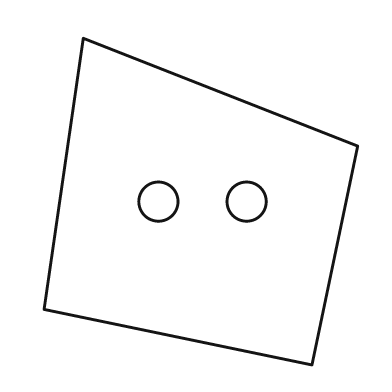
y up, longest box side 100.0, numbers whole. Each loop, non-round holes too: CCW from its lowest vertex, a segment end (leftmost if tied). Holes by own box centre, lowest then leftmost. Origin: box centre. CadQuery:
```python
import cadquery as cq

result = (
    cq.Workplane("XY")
    .moveTo(34.0, -50.0)
    .lineTo(48.0, 17.0)
    .lineTo(-36.0, 50.0)
    .lineTo(-48.0, -33.0)
    .close()
    .moveTo(-13.0, 0.0)
    .circle(6.0)
    .moveTo(14.0, 0.0)
    .circle(6.0)
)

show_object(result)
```